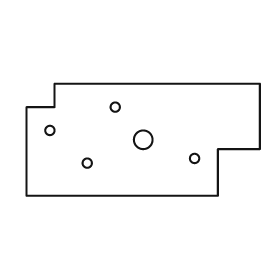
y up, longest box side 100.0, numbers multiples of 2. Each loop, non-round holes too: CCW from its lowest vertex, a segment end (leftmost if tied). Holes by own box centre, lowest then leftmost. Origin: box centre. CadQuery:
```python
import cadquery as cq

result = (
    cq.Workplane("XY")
    .moveTo(-50.0, -24.0)
    .lineTo(32.0, -24.0)
    .lineTo(32.0, -4.0)
    .lineTo(50.0, -4.0)
    .lineTo(50.0, 24.0)
    .lineTo(-38.0, 24.0)
    .lineTo(-38.0, 14.0)
    .lineTo(-50.0, 14.0)
    .close()
    .moveTo(-24.0, -10.0)
    .circle(2.0)
    .moveTo(22.0, -8.0)
    .circle(2.0)
    .moveTo(0.0, 0.0)
    .circle(4.0)
    .moveTo(-40.0, 4.0)
    .circle(2.0)
    .moveTo(-12.0, 14.0)
    .circle(2.0)
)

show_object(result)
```